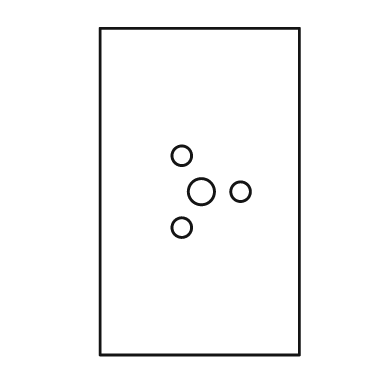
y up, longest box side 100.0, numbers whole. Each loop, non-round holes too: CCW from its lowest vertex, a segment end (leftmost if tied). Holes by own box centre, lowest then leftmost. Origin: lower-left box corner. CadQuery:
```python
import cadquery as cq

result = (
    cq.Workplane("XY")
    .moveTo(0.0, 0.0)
    .lineTo(61.0, 0.0)
    .lineTo(61.0, 100.0)
    .lineTo(0.0, 100.0)
    .close()
    .moveTo(25.0, 39.0)
    .circle(3.0)
    .moveTo(31.0, 50.0)
    .circle(4.0)
    .moveTo(43.0, 50.0)
    .circle(3.0)
    .moveTo(25.0, 61.0)
    .circle(3.0)
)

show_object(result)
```